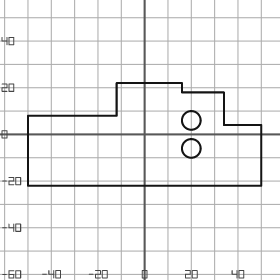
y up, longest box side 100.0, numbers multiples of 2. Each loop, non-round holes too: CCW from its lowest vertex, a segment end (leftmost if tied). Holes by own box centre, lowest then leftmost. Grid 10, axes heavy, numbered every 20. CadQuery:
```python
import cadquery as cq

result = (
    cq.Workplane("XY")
    .moveTo(-50.0, -22.0)
    .lineTo(50.0, -22.0)
    .lineTo(50.0, 4.0)
    .lineTo(34.0, 4.0)
    .lineTo(34.0, 18.0)
    .lineTo(16.0, 18.0)
    .lineTo(16.0, 22.0)
    .lineTo(-12.0, 22.0)
    .lineTo(-12.0, 8.0)
    .lineTo(-50.0, 8.0)
    .close()
    .moveTo(20.0, -6.0)
    .circle(4.0)
    .moveTo(20.0, 6.0)
    .circle(4.0)
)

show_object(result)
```